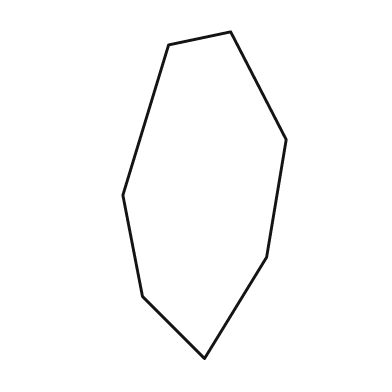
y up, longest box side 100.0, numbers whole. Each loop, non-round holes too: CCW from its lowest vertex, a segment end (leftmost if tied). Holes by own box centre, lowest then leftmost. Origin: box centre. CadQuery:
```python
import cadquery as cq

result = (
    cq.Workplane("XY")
    .moveTo(0.0, -50.0)
    .lineTo(19.0, -19.0)
    .lineTo(25.0, 17.0)
    .lineTo(8.0, 50.0)
    .lineTo(-11.0, 46.0)
    .lineTo(-25.0, 0.0)
    .lineTo(-19.0, -31.0)
    .close()
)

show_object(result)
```